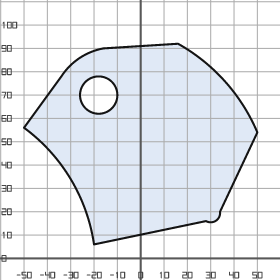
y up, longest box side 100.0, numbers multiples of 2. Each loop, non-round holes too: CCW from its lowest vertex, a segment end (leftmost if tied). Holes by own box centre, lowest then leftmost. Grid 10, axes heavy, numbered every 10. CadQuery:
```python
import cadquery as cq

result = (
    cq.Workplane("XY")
    .moveTo(-20.0, 6.0)
    .lineTo(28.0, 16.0)
    .threePointArc((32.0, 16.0), (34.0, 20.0))
    .lineTo(50.0, 54.0)
    .threePointArc((36.0, 76.0), (16.0, 92.0))
    .lineTo(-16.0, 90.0)
    .threePointArc((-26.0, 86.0), (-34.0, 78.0))
    .lineTo(-50.0, 56.0)
    .threePointArc((-30.0, 34.0), (-20.0, 6.0))
    .close()
    .moveTo(-18.0, 70.0)
    .circle(8.0)
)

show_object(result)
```